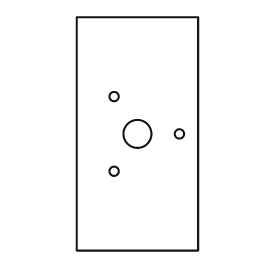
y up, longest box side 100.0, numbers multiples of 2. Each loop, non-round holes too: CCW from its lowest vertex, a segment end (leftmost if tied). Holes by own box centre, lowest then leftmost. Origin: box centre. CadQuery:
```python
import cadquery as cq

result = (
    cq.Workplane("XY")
    .moveTo(-26.0, -50.0)
    .lineTo(26.0, -50.0)
    .lineTo(26.0, 50.0)
    .lineTo(-26.0, 50.0)
    .close()
    .moveTo(-10.0, -16.0)
    .circle(2.0)
    .moveTo(0.0, 0.0)
    .circle(6.0)
    .moveTo(18.0, 0.0)
    .circle(2.0)
    .moveTo(-10.0, 16.0)
    .circle(2.0)
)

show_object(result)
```